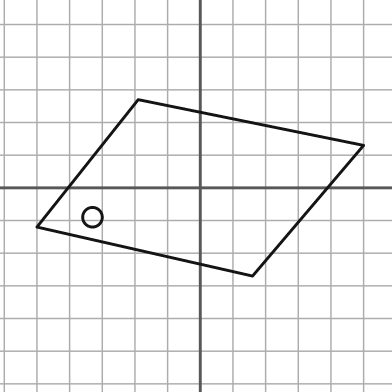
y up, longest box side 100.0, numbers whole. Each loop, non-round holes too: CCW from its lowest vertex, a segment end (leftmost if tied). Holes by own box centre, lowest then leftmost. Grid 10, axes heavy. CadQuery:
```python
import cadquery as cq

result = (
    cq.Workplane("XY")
    .moveTo(16.0, -27.0)
    .lineTo(50.0, 13.0)
    .lineTo(-19.0, 27.0)
    .lineTo(-50.0, -12.0)
    .close()
    .moveTo(-33.0, -9.0)
    .circle(3.0)
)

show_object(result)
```